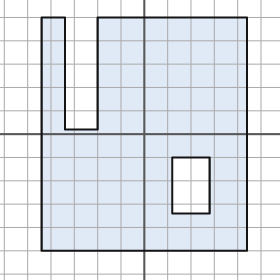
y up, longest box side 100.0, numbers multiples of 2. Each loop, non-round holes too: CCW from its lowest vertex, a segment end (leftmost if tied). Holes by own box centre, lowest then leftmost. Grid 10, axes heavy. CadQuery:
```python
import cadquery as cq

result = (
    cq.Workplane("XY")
    .moveTo(-44.0, -50.0)
    .lineTo(44.0, -50.0)
    .lineTo(44.0, 50.0)
    .lineTo(-20.0, 50.0)
    .lineTo(-20.0, 2.0)
    .lineTo(-34.0, 2.0)
    .lineTo(-34.0, 50.0)
    .lineTo(-44.0, 50.0)
    .close()
    .moveTo(12.0, -34.0)
    .lineTo(28.0, -34.0)
    .lineTo(28.0, -10.0)
    .lineTo(12.0, -10.0)
    .close()
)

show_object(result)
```